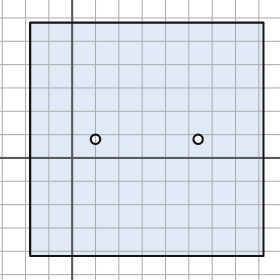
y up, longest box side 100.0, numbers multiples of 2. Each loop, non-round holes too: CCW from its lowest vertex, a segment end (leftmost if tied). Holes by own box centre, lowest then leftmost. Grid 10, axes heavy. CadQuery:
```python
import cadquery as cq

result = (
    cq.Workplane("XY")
    .moveTo(-18.0, -42.0)
    .lineTo(82.0, -42.0)
    .lineTo(82.0, 58.0)
    .lineTo(-18.0, 58.0)
    .close()
    .moveTo(10.0, 8.0)
    .circle(2.0)
    .moveTo(54.0, 8.0)
    .circle(2.0)
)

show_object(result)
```